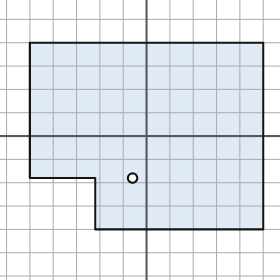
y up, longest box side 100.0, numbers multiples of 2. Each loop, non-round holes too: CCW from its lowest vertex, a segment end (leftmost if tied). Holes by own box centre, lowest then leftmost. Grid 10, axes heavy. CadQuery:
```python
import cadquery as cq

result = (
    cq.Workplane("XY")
    .moveTo(-22.0, -40.0)
    .lineTo(50.0, -40.0)
    .lineTo(50.0, 40.0)
    .lineTo(-50.0, 40.0)
    .lineTo(-50.0, -18.0)
    .lineTo(-22.0, -18.0)
    .close()
    .moveTo(-6.0, -18.0)
    .circle(2.0)
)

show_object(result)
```